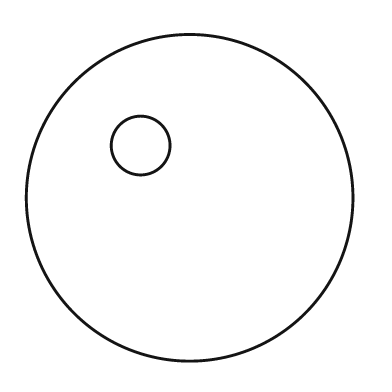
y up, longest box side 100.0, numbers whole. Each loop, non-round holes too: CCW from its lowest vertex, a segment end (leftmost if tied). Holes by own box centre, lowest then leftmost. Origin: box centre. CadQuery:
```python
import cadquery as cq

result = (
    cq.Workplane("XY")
    .moveTo(0.0, 0.0)
    .circle(50.0)
    .moveTo(-15.0, 16.0)
    .circle(9.0)
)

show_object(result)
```